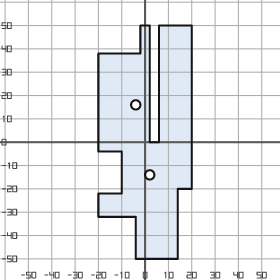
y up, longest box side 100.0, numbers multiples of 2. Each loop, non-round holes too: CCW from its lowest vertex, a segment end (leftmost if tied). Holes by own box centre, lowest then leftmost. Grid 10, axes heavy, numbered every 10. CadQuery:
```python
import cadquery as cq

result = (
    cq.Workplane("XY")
    .moveTo(-4.0, -50.0)
    .lineTo(14.0, -50.0)
    .lineTo(14.0, -20.0)
    .lineTo(20.0, -20.0)
    .lineTo(20.0, 50.0)
    .lineTo(6.0, 50.0)
    .lineTo(6.0, 0.0)
    .lineTo(2.0, 0.0)
    .lineTo(2.0, 50.0)
    .lineTo(-2.0, 50.0)
    .lineTo(-2.0, 38.0)
    .lineTo(-20.0, 38.0)
    .lineTo(-20.0, -4.0)
    .lineTo(-10.0, -4.0)
    .lineTo(-10.0, -22.0)
    .lineTo(-20.0, -22.0)
    .lineTo(-20.0, -32.0)
    .lineTo(-4.0, -32.0)
    .close()
    .moveTo(2.0, -14.0)
    .circle(2.0)
    .moveTo(-4.0, 16.0)
    .circle(2.0)
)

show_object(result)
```